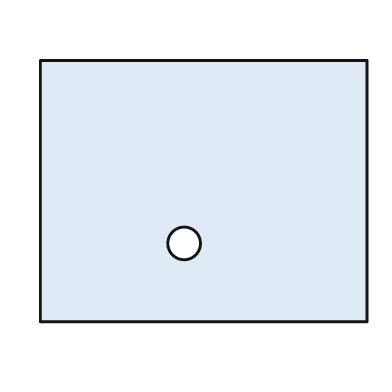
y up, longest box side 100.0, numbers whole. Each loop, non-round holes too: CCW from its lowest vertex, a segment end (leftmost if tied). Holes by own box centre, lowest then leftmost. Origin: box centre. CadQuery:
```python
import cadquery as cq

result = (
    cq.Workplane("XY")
    .moveTo(-50.0, -40.0)
    .lineTo(50.0, -40.0)
    .lineTo(50.0, 40.0)
    .lineTo(-50.0, 40.0)
    .close()
    .moveTo(-6.0, -16.0)
    .circle(5.0)
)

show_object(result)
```